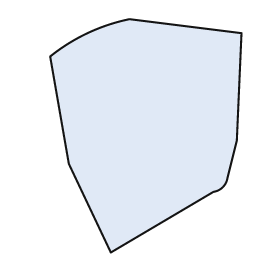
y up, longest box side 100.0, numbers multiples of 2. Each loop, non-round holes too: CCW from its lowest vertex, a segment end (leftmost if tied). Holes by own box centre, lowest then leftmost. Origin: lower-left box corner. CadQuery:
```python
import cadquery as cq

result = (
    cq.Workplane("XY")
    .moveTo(26.0, 0.0)
    .lineTo(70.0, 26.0)
    .threePointArc((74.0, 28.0), (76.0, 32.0))
    .lineTo(80.0, 48.0)
    .lineTo(82.0, 94.0)
    .lineTo(34.0, 100.0)
    .threePointArc((16.0, 94.0), (0.0, 84.0))
    .lineTo(8.0, 38.0)
    .close()
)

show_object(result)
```